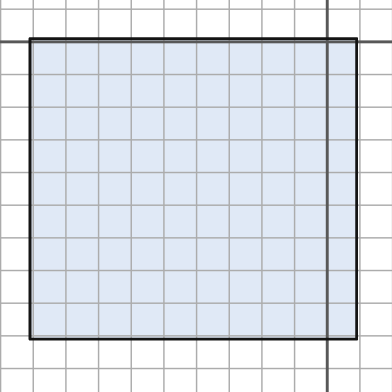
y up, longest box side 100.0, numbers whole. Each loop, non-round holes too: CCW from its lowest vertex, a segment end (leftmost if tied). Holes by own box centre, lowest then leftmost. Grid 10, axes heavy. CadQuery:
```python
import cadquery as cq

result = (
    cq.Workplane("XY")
    .moveTo(-91.0, -91.0)
    .lineTo(9.0, -91.0)
    .lineTo(9.0, 1.0)
    .lineTo(-91.0, 1.0)
    .close()
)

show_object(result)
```